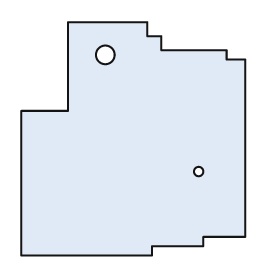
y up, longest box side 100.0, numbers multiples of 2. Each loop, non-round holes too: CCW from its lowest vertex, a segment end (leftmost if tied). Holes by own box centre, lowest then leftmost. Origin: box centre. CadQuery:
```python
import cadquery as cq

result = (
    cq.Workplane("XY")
    .moveTo(-48.0, -50.0)
    .lineTo(8.0, -50.0)
    .lineTo(8.0, -46.0)
    .lineTo(30.0, -46.0)
    .lineTo(30.0, -42.0)
    .lineTo(48.0, -42.0)
    .lineTo(48.0, 34.0)
    .lineTo(40.0, 34.0)
    .lineTo(40.0, 38.0)
    .lineTo(12.0, 38.0)
    .lineTo(12.0, 44.0)
    .lineTo(6.0, 44.0)
    .lineTo(6.0, 50.0)
    .lineTo(-28.0, 50.0)
    .lineTo(-28.0, 12.0)
    .lineTo(-48.0, 12.0)
    .close()
    .moveTo(28.0, -14.0)
    .circle(2.0)
    .moveTo(-12.0, 36.0)
    .circle(4.0)
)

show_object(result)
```